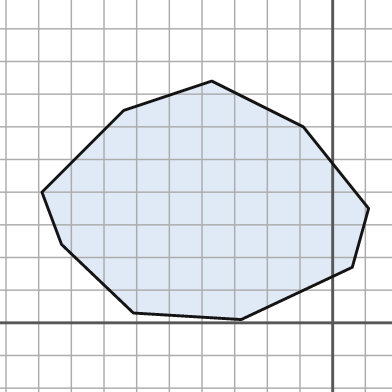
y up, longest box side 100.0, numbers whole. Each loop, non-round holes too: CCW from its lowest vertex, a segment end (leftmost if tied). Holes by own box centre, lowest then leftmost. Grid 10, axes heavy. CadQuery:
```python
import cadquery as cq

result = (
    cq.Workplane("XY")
    .moveTo(-28.0, 1.0)
    .lineTo(6.0, 17.0)
    .lineTo(11.0, 35.0)
    .lineTo(-9.0, 60.0)
    .lineTo(-37.0, 74.0)
    .lineTo(-64.0, 65.0)
    .lineTo(-89.0, 40.0)
    .lineTo(-83.0, 24.0)
    .lineTo(-61.0, 3.0)
    .close()
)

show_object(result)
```